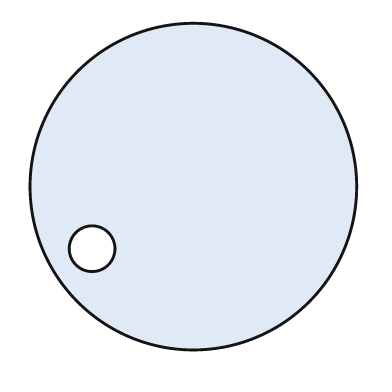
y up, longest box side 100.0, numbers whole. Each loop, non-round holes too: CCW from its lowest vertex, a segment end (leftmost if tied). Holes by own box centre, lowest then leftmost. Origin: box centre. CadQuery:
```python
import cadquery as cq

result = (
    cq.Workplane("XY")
    .moveTo(0.0, 0.0)
    .circle(50.0)
    .moveTo(-31.0, -19.0)
    .circle(7.0)
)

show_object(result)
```